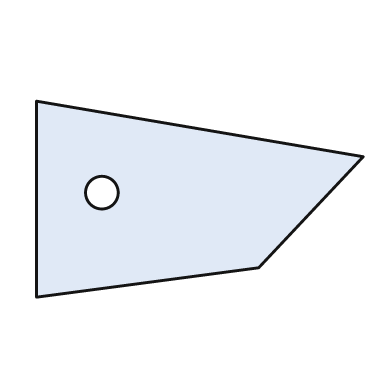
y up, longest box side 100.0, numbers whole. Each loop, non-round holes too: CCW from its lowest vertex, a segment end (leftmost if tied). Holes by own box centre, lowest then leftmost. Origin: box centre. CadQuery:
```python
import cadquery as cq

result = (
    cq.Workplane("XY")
    .moveTo(-50.0, -30.0)
    .lineTo(18.0, -21.0)
    .lineTo(50.0, 13.0)
    .lineTo(-50.0, 30.0)
    .close()
    .moveTo(-30.0, 2.0)
    .circle(5.0)
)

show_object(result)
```